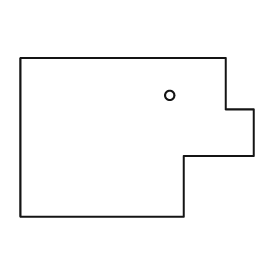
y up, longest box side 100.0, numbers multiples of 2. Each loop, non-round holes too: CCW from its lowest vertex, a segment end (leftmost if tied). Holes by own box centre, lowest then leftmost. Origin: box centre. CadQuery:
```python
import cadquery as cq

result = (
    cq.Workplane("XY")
    .moveTo(-50.0, -34.0)
    .lineTo(20.0, -34.0)
    .lineTo(20.0, -8.0)
    .lineTo(50.0, -8.0)
    .lineTo(50.0, 12.0)
    .lineTo(38.0, 12.0)
    .lineTo(38.0, 34.0)
    .lineTo(-50.0, 34.0)
    .close()
    .moveTo(14.0, 18.0)
    .circle(2.0)
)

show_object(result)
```